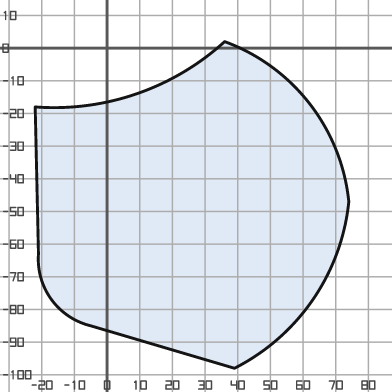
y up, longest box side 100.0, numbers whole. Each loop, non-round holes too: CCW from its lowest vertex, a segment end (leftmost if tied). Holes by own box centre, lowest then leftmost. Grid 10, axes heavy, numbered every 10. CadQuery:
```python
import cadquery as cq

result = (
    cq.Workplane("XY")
    .moveTo(39.0, -98.0)
    .threePointArc((63.0, -77.0), (74.0, -47.0))
    .threePointArc((62.0, -17.0), (36.0, 2.0))
    .threePointArc((9.0, -14.0), (-22.0, -18.0))
    .lineTo(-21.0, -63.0)
    .threePointArc((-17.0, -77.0), (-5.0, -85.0))
    .close()
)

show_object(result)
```